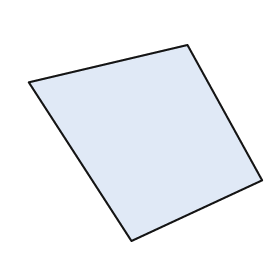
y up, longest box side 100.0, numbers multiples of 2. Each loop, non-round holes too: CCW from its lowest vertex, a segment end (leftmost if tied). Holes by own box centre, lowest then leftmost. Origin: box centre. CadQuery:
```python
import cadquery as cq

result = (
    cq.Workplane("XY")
    .moveTo(-6.0, -42.0)
    .lineTo(50.0, -16.0)
    .lineTo(18.0, 42.0)
    .lineTo(-50.0, 26.0)
    .close()
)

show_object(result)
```